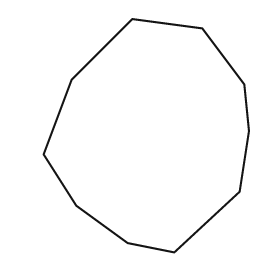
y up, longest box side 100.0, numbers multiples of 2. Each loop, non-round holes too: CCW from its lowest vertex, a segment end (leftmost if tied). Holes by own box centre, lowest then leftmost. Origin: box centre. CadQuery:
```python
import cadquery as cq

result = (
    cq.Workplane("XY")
    .moveTo(12.0, -50.0)
    .lineTo(40.0, -24.0)
    .lineTo(44.0, 2.0)
    .lineTo(42.0, 22.0)
    .lineTo(24.0, 46.0)
    .lineTo(-6.0, 50.0)
    .lineTo(-32.0, 24.0)
    .lineTo(-44.0, -8.0)
    .lineTo(-30.0, -30.0)
    .lineTo(-8.0, -46.0)
    .close()
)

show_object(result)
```